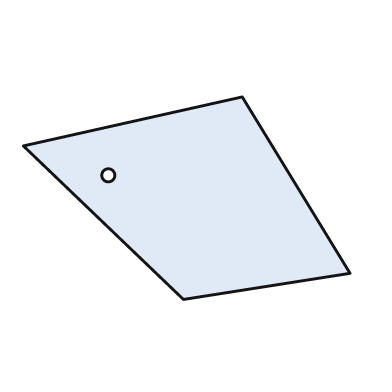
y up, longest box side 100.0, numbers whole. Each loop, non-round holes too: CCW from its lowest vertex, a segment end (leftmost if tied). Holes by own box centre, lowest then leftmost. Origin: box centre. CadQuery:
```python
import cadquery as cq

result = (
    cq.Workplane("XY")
    .moveTo(-1.0, -31.0)
    .lineTo(50.0, -23.0)
    .lineTo(17.0, 31.0)
    .lineTo(-50.0, 16.0)
    .close()
    .moveTo(-24.0, 7.0)
    .circle(2.0)
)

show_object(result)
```